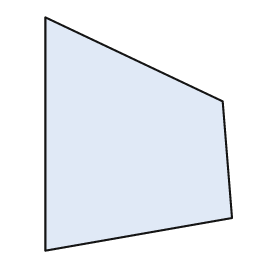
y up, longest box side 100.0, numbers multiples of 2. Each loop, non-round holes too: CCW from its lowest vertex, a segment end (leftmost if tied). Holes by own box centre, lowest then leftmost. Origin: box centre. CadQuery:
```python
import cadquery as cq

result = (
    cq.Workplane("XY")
    .moveTo(-40.0, -50.0)
    .lineTo(40.0, -36.0)
    .lineTo(36.0, 14.0)
    .lineTo(-40.0, 50.0)
    .close()
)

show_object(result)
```